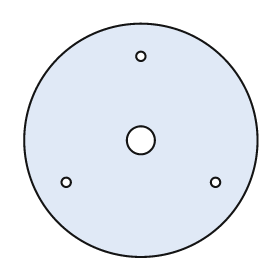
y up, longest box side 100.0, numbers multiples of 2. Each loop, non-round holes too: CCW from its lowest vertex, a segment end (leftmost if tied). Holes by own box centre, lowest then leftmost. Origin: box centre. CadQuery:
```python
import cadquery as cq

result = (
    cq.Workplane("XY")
    .moveTo(0.0, 0.0)
    .circle(50.0)
    .moveTo(-32.0, -18.0)
    .circle(2.0)
    .moveTo(32.0, -18.0)
    .circle(2.0)
    .moveTo(0.0, 0.0)
    .circle(6.0)
    .moveTo(0.0, 36.0)
    .circle(2.0)
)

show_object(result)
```